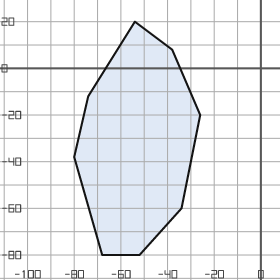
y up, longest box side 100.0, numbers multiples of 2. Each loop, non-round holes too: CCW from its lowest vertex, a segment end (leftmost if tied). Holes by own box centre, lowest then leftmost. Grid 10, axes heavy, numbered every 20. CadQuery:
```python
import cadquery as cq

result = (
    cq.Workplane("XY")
    .moveTo(-68.0, -80.0)
    .lineTo(-52.0, -80.0)
    .lineTo(-34.0, -60.0)
    .lineTo(-26.0, -20.0)
    .lineTo(-38.0, 8.0)
    .lineTo(-54.0, 20.0)
    .lineTo(-74.0, -12.0)
    .lineTo(-80.0, -38.0)
    .close()
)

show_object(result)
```